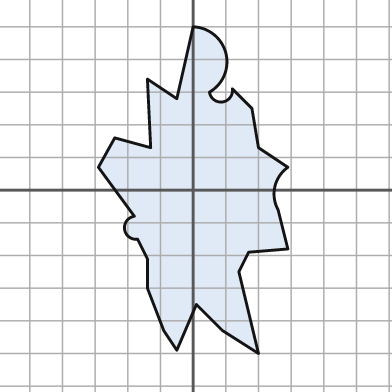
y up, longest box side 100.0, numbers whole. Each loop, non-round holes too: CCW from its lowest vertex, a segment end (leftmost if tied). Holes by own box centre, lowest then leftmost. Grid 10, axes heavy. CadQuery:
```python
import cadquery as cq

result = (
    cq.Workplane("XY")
    .moveTo(20.0, -50.0)
    .lineTo(14.0, -25.0)
    .lineTo(17.0, -19.0)
    .lineTo(29.0, -18.0)
    .lineTo(26.0, -6.0)
    .threePointArc((25.0, 1.0), (29.0, 7.0))
    .lineTo(20.0, 13.0)
    .lineTo(18.0, 25.0)
    .lineTo(12.0, 31.0)
    .threePointArc((9.0, 27.0), (5.0, 30.0))
    .threePointArc((10.0, 42.0), (0.0, 50.0))
    .lineTo(-5.0, 28.0)
    .lineTo(-14.0, 34.0)
    .lineTo(-13.0, 13.0)
    .lineTo(-24.0, 16.0)
    .lineTo(-29.0, 7.0)
    .lineTo(-18.0, -8.0)
    .threePointArc((-21.0, -12.0), (-17.0, -15.0))
    .lineTo(-14.0, -21.0)
    .lineTo(-14.0, -30.0)
    .lineTo(-9.0, -43.0)
    .lineTo(-5.0, -49.0)
    .lineTo(1.0, -35.0)
    .lineTo(9.0, -43.0)
    .close()
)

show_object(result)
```